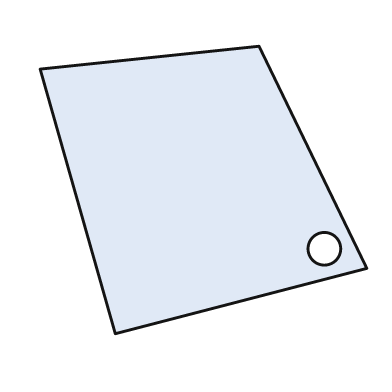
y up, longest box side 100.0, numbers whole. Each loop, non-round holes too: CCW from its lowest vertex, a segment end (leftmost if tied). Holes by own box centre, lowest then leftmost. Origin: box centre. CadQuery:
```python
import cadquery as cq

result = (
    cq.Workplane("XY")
    .moveTo(-27.0, -44.0)
    .lineTo(50.0, -24.0)
    .lineTo(17.0, 44.0)
    .lineTo(-50.0, 37.0)
    .close()
    .moveTo(37.0, -18.0)
    .circle(5.0)
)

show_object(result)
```